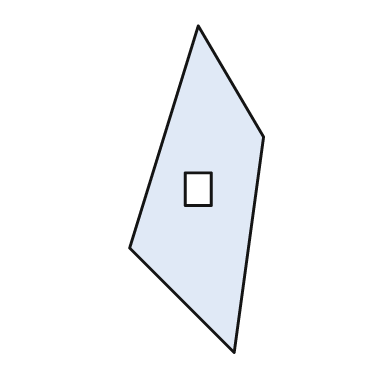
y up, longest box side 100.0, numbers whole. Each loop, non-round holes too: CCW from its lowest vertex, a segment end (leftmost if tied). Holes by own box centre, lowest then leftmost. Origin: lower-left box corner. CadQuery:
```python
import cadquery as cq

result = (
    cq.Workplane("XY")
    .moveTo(32.0, 0.0)
    .lineTo(41.0, 66.0)
    .lineTo(21.0, 100.0)
    .lineTo(0.0, 32.0)
    .close()
    .moveTo(17.0, 45.0)
    .lineTo(25.0, 45.0)
    .lineTo(25.0, 55.0)
    .lineTo(17.0, 55.0)
    .close()
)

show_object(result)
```